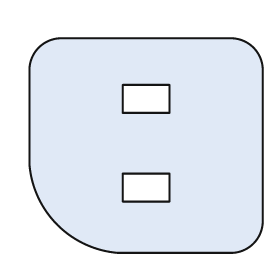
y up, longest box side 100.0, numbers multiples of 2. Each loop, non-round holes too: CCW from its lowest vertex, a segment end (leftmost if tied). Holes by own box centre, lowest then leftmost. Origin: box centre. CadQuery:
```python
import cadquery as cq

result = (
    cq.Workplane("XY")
    .moveTo(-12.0, -46.0)
    .lineTo(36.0, -46.0)
    .threePointArc((46.0, -42.0), (50.0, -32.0))
    .lineTo(50.0, 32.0)
    .threePointArc((46.0, 42.0), (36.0, 46.0))
    .lineTo(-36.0, 46.0)
    .threePointArc((-46.0, 42.0), (-50.0, 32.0))
    .lineTo(-50.0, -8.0)
    .threePointArc((-38.0, -34.0), (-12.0, -46.0))
    .close()
    .moveTo(-10.0, -24.0)
    .lineTo(10.0, -24.0)
    .lineTo(10.0, -12.0)
    .lineTo(-10.0, -12.0)
    .close()
    .moveTo(-10.0, 14.0)
    .lineTo(10.0, 14.0)
    .lineTo(10.0, 26.0)
    .lineTo(-10.0, 26.0)
    .close()
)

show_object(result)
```